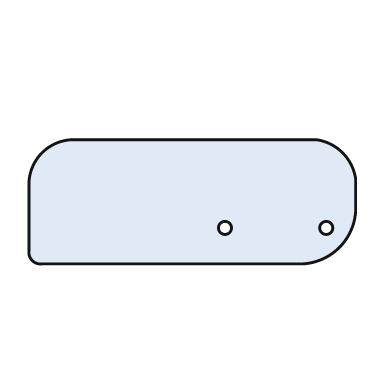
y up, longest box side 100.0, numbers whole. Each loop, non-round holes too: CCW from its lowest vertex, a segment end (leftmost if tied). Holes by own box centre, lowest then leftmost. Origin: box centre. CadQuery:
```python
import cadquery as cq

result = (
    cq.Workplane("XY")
    .moveTo(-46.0, -19.0)
    .lineTo(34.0, -19.0)
    .threePointArc((45.0, -14.0), (50.0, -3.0))
    .lineTo(50.0, 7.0)
    .threePointArc((46.0, 15.0), (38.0, 19.0))
    .lineTo(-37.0, 19.0)
    .threePointArc((-46.0, 15.0), (-50.0, 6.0))
    .lineTo(-50.0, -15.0)
    .threePointArc((-49.0, -18.0), (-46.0, -19.0))
    .close()
    .moveTo(10.0, -8.0)
    .circle(2.0)
    .moveTo(41.0, -8.0)
    .circle(2.0)
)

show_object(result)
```